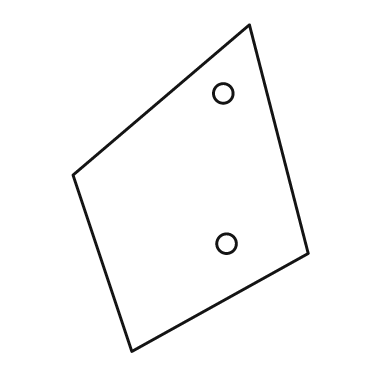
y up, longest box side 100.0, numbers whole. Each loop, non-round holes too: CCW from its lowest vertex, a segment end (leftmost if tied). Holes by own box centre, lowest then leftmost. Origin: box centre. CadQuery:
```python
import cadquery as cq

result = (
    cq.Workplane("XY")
    .moveTo(-18.0, -50.0)
    .lineTo(36.0, -20.0)
    .lineTo(18.0, 50.0)
    .lineTo(-36.0, 4.0)
    .close()
    .moveTo(11.0, -17.0)
    .circle(3.0)
    .moveTo(10.0, 29.0)
    .circle(3.0)
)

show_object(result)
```